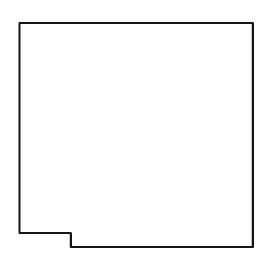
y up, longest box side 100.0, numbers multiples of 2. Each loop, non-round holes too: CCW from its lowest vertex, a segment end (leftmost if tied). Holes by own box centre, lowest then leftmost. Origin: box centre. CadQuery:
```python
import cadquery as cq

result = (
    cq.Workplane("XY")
    .moveTo(-28.0, -48.0)
    .lineTo(50.0, -48.0)
    .lineTo(50.0, 48.0)
    .lineTo(-50.0, 48.0)
    .lineTo(-50.0, -42.0)
    .lineTo(-28.0, -42.0)
    .close()
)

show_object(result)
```